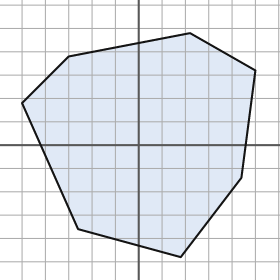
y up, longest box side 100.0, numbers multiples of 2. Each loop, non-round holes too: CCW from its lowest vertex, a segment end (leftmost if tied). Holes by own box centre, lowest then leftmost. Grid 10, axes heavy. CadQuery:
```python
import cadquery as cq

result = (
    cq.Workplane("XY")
    .moveTo(18.0, -48.0)
    .lineTo(44.0, -14.0)
    .lineTo(50.0, 32.0)
    .lineTo(22.0, 48.0)
    .lineTo(-30.0, 38.0)
    .lineTo(-50.0, 18.0)
    .lineTo(-26.0, -36.0)
    .close()
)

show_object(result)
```